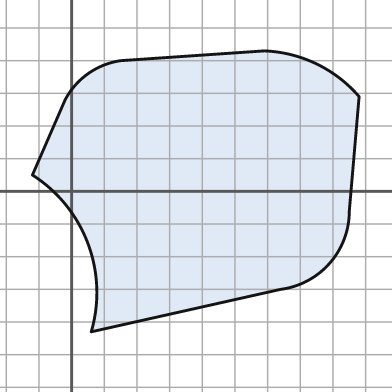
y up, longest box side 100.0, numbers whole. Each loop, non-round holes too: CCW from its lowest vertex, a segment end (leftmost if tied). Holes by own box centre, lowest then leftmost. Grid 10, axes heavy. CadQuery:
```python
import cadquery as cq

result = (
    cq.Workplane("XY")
    .moveTo(6.0, -43.0)
    .lineTo(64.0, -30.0)
    .threePointArc((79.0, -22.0), (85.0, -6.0))
    .lineTo(88.0, 29.0)
    .threePointArc((75.0, 39.0), (59.0, 43.0))
    .lineTo(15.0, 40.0)
    .threePointArc((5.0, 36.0), (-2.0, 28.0))
    .lineTo(-12.0, 5.0)
    .threePointArc((5.0, -16.0), (6.0, -43.0))
    .close()
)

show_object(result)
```